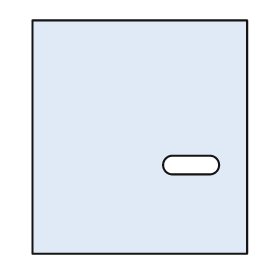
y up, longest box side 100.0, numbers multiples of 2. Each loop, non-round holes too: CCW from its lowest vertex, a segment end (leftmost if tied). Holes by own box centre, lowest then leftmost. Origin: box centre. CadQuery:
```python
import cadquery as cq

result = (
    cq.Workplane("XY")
    .moveTo(-46.0, -50.0)
    .lineTo(46.0, -50.0)
    .lineTo(46.0, 50.0)
    .lineTo(-46.0, 50.0)
    .close()
    .moveTo(14.0, -16.0)
    .lineTo(30.0, -16.0)
    .threePointArc((34.0, -12.0), (30.0, -8.0))
    .lineTo(14.0, -8.0)
    .threePointArc((10.0, -12.0), (14.0, -16.0))
    .close()
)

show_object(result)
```